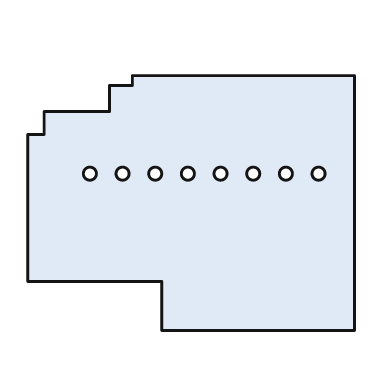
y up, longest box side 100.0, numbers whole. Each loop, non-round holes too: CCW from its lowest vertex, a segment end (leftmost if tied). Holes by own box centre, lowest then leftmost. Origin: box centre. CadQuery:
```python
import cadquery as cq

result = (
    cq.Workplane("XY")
    .moveTo(-9.0, -39.0)
    .lineTo(50.0, -39.0)
    .lineTo(50.0, 39.0)
    .lineTo(-18.0, 39.0)
    .lineTo(-18.0, 36.0)
    .lineTo(-25.0, 36.0)
    .lineTo(-25.0, 28.0)
    .lineTo(-45.0, 28.0)
    .lineTo(-45.0, 21.0)
    .lineTo(-50.0, 21.0)
    .lineTo(-50.0, -24.0)
    .lineTo(-9.0, -24.0)
    .close()
    .moveTo(-31.0, 9.0)
    .circle(2.0)
    .moveTo(-21.0, 9.0)
    .circle(2.0)
    .moveTo(-11.0, 9.0)
    .circle(2.0)
    .moveTo(-1.0, 9.0)
    .circle(2.0)
    .moveTo(9.0, 9.0)
    .circle(2.0)
    .moveTo(19.0, 9.0)
    .circle(2.0)
    .moveTo(29.0, 9.0)
    .circle(2.0)
    .moveTo(39.0, 9.0)
    .circle(2.0)
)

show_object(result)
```